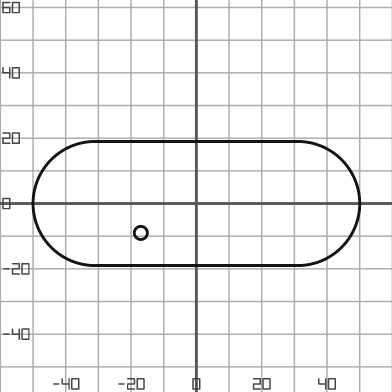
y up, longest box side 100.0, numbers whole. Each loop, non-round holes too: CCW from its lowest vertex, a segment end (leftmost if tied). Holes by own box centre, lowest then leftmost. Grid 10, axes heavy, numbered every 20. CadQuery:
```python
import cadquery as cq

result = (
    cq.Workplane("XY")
    .moveTo(-31.0, -19.0)
    .lineTo(31.0, -19.0)
    .threePointArc((50.0, 0.0), (31.0, 19.0))
    .lineTo(-31.0, 19.0)
    .threePointArc((-50.0, 0.0), (-31.0, -19.0))
    .close()
    .moveTo(-17.0, -9.0)
    .circle(2.0)
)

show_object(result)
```